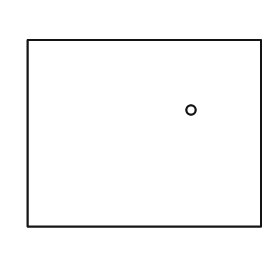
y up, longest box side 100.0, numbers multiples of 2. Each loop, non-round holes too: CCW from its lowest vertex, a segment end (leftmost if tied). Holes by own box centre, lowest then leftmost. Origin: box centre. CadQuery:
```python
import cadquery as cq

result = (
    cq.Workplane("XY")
    .moveTo(-50.0, -40.0)
    .lineTo(50.0, -40.0)
    .lineTo(50.0, 40.0)
    .lineTo(-50.0, 40.0)
    .close()
    .moveTo(20.0, 10.0)
    .circle(2.0)
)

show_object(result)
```